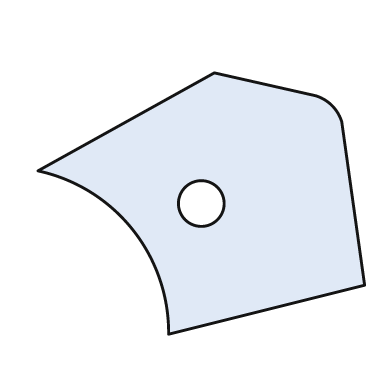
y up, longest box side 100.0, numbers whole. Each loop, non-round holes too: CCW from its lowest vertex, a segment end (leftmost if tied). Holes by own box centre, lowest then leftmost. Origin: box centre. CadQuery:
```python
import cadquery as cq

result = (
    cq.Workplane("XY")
    .moveTo(-10.0, -40.0)
    .lineTo(50.0, -25.0)
    .lineTo(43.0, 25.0)
    .threePointArc((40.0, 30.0), (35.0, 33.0))
    .lineTo(4.0, 40.0)
    .lineTo(-50.0, 10.0)
    .threePointArc((-21.0, -8.0), (-10.0, -40.0))
    .close()
    .moveTo(0.0, 0.0)
    .circle(7.0)
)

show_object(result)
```